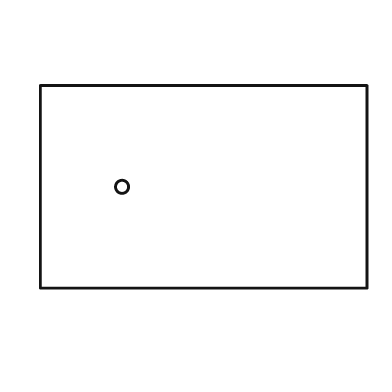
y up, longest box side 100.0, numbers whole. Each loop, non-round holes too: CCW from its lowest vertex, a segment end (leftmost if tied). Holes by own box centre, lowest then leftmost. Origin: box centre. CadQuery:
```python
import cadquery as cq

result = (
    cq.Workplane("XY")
    .moveTo(-50.0, -31.0)
    .lineTo(50.0, -31.0)
    .lineTo(50.0, 31.0)
    .lineTo(-50.0, 31.0)
    .close()
    .moveTo(-25.0, 0.0)
    .circle(2.0)
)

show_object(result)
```